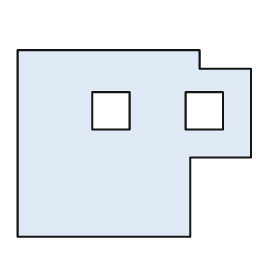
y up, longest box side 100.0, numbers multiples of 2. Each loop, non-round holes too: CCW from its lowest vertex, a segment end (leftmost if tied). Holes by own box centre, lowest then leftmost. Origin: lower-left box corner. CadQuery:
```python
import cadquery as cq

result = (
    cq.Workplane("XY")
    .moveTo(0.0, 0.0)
    .lineTo(74.0, 0.0)
    .lineTo(74.0, 34.0)
    .lineTo(100.0, 34.0)
    .lineTo(100.0, 72.0)
    .lineTo(78.0, 72.0)
    .lineTo(78.0, 80.0)
    .lineTo(0.0, 80.0)
    .close()
    .moveTo(32.0, 46.0)
    .lineTo(48.0, 46.0)
    .lineTo(48.0, 62.0)
    .lineTo(32.0, 62.0)
    .close()
    .moveTo(72.0, 46.0)
    .lineTo(88.0, 46.0)
    .lineTo(88.0, 62.0)
    .lineTo(72.0, 62.0)
    .close()
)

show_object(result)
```